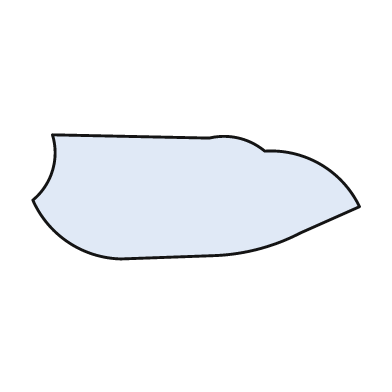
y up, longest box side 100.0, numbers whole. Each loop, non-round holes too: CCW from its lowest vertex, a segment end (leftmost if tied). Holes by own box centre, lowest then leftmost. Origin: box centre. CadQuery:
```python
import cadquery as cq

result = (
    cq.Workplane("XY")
    .moveTo(-23.0, -19.0)
    .lineTo(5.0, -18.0)
    .threePointArc((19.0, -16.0), (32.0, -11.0))
    .lineTo(50.0, -3.0)
    .threePointArc((38.0, 10.0), (21.0, 14.0))
    .threePointArc((13.0, 18.0), (4.0, 18.0))
    .lineTo(-44.0, 19.0)
    .threePointArc((-44.0, 8.0), (-50.0, -1.0))
    .threePointArc((-39.0, -14.0), (-23.0, -19.0))
    .close()
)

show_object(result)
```